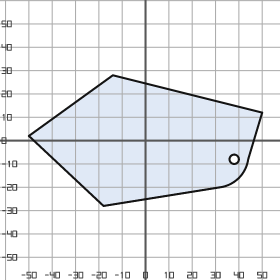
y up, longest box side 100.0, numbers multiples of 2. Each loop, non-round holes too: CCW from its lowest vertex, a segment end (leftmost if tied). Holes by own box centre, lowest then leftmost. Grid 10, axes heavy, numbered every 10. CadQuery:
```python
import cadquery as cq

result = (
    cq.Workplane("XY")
    .moveTo(-18.0, -28.0)
    .lineTo(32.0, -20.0)
    .threePointArc((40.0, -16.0), (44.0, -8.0))
    .lineTo(50.0, 12.0)
    .lineTo(-14.0, 28.0)
    .lineTo(-50.0, 2.0)
    .close()
    .moveTo(38.0, -8.0)
    .circle(2.0)
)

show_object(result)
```